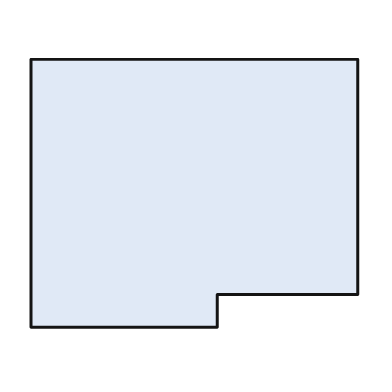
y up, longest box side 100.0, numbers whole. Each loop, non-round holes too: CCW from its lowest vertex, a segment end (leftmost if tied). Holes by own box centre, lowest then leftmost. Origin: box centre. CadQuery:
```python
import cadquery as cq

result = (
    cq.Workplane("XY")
    .moveTo(-50.0, -41.0)
    .lineTo(7.0, -41.0)
    .lineTo(7.0, -31.0)
    .lineTo(50.0, -31.0)
    .lineTo(50.0, 41.0)
    .lineTo(-50.0, 41.0)
    .close()
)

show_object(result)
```